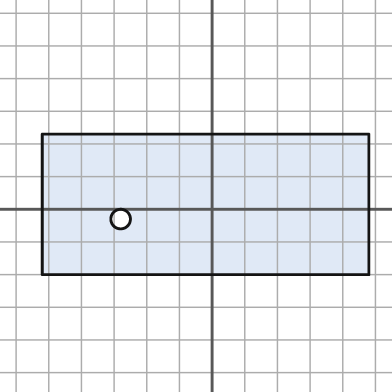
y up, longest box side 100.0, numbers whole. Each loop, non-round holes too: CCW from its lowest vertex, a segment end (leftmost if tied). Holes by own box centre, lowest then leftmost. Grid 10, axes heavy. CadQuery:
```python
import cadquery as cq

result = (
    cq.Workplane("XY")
    .moveTo(-52.0, -20.0)
    .lineTo(48.0, -20.0)
    .lineTo(48.0, 23.0)
    .lineTo(-52.0, 23.0)
    .close()
    .moveTo(-28.0, -3.0)
    .circle(3.0)
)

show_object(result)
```